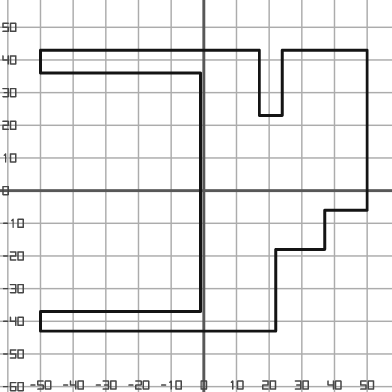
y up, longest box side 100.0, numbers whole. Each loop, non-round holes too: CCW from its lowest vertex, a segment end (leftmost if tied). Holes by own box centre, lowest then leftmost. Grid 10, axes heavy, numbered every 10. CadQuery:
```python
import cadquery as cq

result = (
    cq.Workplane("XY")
    .moveTo(-50.0, -43.0)
    .lineTo(22.0, -43.0)
    .lineTo(22.0, -18.0)
    .lineTo(37.0, -18.0)
    .lineTo(37.0, -6.0)
    .lineTo(50.0, -6.0)
    .lineTo(50.0, 43.0)
    .lineTo(24.0, 43.0)
    .lineTo(24.0, 23.0)
    .lineTo(17.0, 23.0)
    .lineTo(17.0, 43.0)
    .lineTo(-50.0, 43.0)
    .lineTo(-50.0, 36.0)
    .lineTo(-1.0, 36.0)
    .lineTo(-1.0, -37.0)
    .lineTo(-50.0, -37.0)
    .close()
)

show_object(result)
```